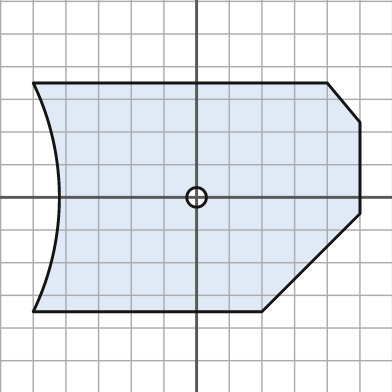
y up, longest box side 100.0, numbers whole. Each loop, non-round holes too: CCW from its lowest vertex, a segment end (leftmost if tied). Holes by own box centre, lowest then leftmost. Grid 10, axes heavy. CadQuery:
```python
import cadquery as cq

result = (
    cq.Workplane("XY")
    .moveTo(-50.0, -35.0)
    .lineTo(20.0, -35.0)
    .lineTo(50.0, -5.0)
    .lineTo(50.0, 23.0)
    .lineTo(40.0, 35.0)
    .lineTo(-50.0, 35.0)
    .threePointArc((-42.0, 0.0), (-50.0, -35.0))
    .close()
    .moveTo(0.0, 0.0)
    .circle(3.0)
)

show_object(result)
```